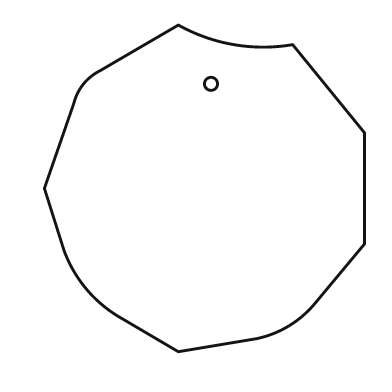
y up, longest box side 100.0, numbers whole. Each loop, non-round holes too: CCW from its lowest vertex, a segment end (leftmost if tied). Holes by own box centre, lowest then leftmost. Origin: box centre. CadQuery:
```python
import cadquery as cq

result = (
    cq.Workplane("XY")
    .moveTo(-8.0, -50.0)
    .lineTo(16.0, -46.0)
    .threePointArc((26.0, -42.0), (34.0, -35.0))
    .lineTo(49.0, -17.0)
    .lineTo(49.0, 17.0)
    .lineTo(27.0, 44.0)
    .threePointArc((9.0, 44.0), (-8.0, 50.0))
    .lineTo(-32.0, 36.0)
    .threePointArc((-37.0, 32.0), (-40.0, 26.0))
    .lineTo(-49.0, 0.0)
    .lineTo(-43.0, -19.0)
    .threePointArc((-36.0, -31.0), (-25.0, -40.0))
    .close()
    .moveTo(2.0, 32.0)
    .circle(2.0)
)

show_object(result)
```